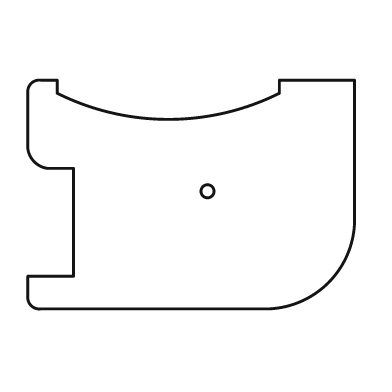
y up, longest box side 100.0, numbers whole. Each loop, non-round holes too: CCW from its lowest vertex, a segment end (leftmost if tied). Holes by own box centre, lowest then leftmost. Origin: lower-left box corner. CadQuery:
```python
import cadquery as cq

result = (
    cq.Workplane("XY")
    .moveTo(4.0, 0.0)
    .lineTo(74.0, 0.0)
    .threePointArc((92.0, 8.0), (100.0, 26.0))
    .lineTo(100.0, 70.0)
    .lineTo(77.0, 70.0)
    .lineTo(77.0, 66.0)
    .threePointArc((43.0, 58.0), (9.0, 66.0))
    .lineTo(9.0, 70.0)
    .lineTo(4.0, 70.0)
    .threePointArc((1.0, 69.0), (0.0, 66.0))
    .lineTo(0.0, 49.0)
    .threePointArc((2.0, 45.0), (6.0, 43.0))
    .lineTo(14.0, 43.0)
    .lineTo(14.0, 10.0)
    .lineTo(0.0, 10.0)
    .lineTo(0.0, 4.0)
    .threePointArc((1.0, 1.0), (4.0, 0.0))
    .close()
    .moveTo(55.0, 36.0)
    .circle(2.0)
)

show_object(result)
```